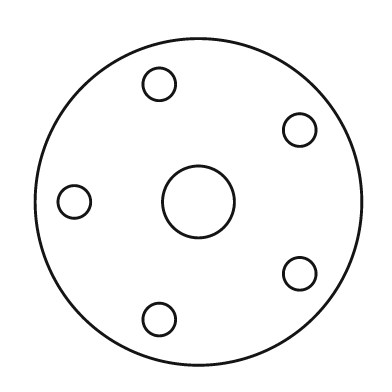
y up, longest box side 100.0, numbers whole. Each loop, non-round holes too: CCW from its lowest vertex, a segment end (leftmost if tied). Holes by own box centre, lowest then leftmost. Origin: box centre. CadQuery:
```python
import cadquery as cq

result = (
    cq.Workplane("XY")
    .moveTo(0.0, 0.0)
    .circle(50.0)
    .moveTo(-12.0, -36.0)
    .circle(5.0)
    .moveTo(31.0, -22.0)
    .circle(5.0)
    .moveTo(-38.0, 0.0)
    .circle(5.0)
    .moveTo(0.0, 0.0)
    .circle(11.0)
    .moveTo(31.0, 22.0)
    .circle(5.0)
    .moveTo(-12.0, 36.0)
    .circle(5.0)
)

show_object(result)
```